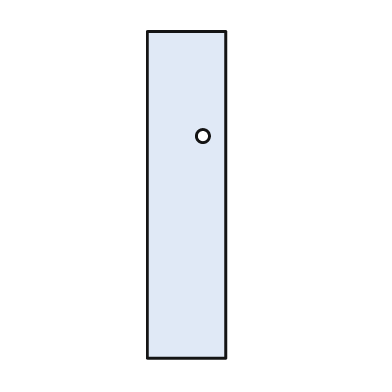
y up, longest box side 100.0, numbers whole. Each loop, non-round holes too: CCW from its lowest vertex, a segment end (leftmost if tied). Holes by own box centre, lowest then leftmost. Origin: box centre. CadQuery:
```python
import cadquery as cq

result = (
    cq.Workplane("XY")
    .moveTo(-12.0, -50.0)
    .lineTo(12.0, -50.0)
    .lineTo(12.0, 50.0)
    .lineTo(-12.0, 50.0)
    .close()
    .moveTo(5.0, 18.0)
    .circle(2.0)
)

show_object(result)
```